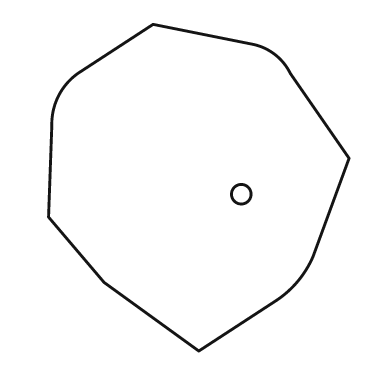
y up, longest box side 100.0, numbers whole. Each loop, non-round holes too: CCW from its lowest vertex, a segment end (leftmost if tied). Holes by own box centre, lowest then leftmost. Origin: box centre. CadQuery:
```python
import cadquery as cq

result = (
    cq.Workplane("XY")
    .moveTo(0.0, -50.0)
    .lineTo(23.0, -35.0)
    .threePointArc((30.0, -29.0), (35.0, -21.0))
    .lineTo(46.0, 9.0)
    .lineTo(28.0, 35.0)
    .threePointArc((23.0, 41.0), (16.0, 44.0))
    .lineTo(-14.0, 50.0)
    .lineTo(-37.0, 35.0)
    .threePointArc((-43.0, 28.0), (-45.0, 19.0))
    .lineTo(-46.0, -9.0)
    .lineTo(-29.0, -29.0)
    .close()
    .moveTo(13.0, -2.0)
    .circle(3.0)
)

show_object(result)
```